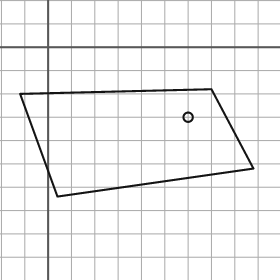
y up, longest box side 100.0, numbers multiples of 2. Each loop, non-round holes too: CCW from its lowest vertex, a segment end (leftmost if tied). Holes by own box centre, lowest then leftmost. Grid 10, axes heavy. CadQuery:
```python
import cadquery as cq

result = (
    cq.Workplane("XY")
    .moveTo(4.0, -64.0)
    .lineTo(88.0, -52.0)
    .lineTo(70.0, -18.0)
    .lineTo(-12.0, -20.0)
    .close()
    .moveTo(60.0, -30.0)
    .circle(2.0)
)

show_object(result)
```